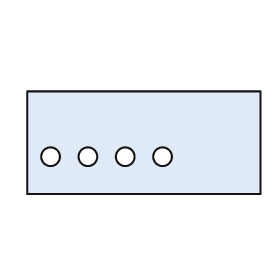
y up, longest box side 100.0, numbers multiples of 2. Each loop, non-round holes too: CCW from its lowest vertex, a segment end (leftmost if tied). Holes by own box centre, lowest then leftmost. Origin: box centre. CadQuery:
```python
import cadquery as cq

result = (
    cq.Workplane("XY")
    .moveTo(-50.0, -22.0)
    .lineTo(50.0, -22.0)
    .lineTo(50.0, 22.0)
    .lineTo(-50.0, 22.0)
    .close()
    .moveTo(-40.0, -6.0)
    .circle(4.0)
    .moveTo(-24.0, -6.0)
    .circle(4.0)
    .moveTo(-8.0, -6.0)
    .circle(4.0)
    .moveTo(8.0, -6.0)
    .circle(4.0)
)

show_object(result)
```